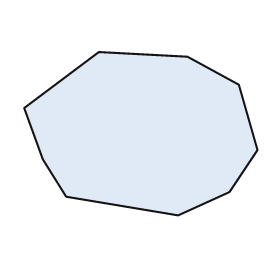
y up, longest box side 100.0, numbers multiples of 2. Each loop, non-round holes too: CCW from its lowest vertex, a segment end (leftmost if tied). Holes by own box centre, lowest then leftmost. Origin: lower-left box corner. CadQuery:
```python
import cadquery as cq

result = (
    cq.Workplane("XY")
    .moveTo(66.0, 0.0)
    .lineTo(88.0, 10.0)
    .lineTo(100.0, 28.0)
    .lineTo(92.0, 56.0)
    .lineTo(70.0, 68.0)
    .lineTo(32.0, 70.0)
    .lineTo(0.0, 46.0)
    .lineTo(8.0, 24.0)
    .lineTo(18.0, 8.0)
    .close()
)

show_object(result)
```